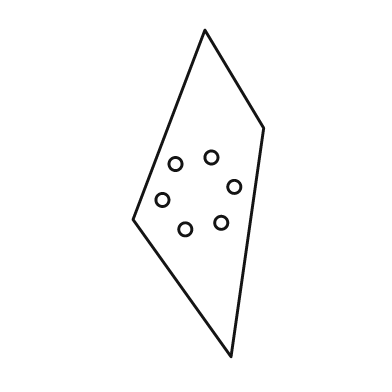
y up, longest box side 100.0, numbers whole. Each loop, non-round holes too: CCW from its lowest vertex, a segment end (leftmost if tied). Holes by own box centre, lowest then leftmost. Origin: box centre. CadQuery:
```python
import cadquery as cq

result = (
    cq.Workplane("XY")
    .moveTo(10.0, -50.0)
    .lineTo(20.0, 20.0)
    .lineTo(2.0, 50.0)
    .lineTo(-20.0, -8.0)
    .close()
    .moveTo(-4.0, -11.0)
    .circle(2.0)
    .moveTo(7.0, -9.0)
    .circle(2.0)
    .moveTo(-11.0, -2.0)
    .circle(2.0)
    .moveTo(11.0, 2.0)
    .circle(2.0)
    .moveTo(-7.0, 9.0)
    .circle(2.0)
    .moveTo(4.0, 11.0)
    .circle(2.0)
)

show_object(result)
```